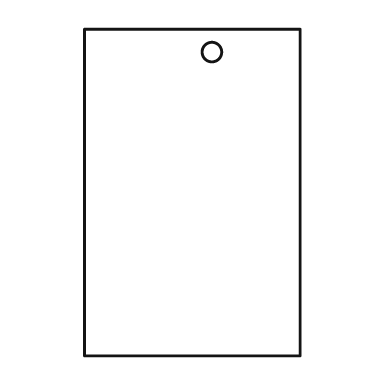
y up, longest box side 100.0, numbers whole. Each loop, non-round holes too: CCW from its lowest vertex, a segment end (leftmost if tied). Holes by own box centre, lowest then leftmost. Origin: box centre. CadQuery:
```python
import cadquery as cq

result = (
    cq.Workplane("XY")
    .moveTo(-33.0, -50.0)
    .lineTo(33.0, -50.0)
    .lineTo(33.0, 50.0)
    .lineTo(-33.0, 50.0)
    .close()
    .moveTo(6.0, 43.0)
    .circle(3.0)
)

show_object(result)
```